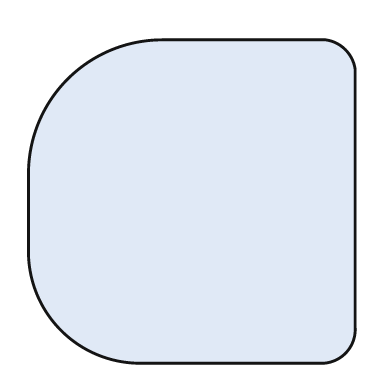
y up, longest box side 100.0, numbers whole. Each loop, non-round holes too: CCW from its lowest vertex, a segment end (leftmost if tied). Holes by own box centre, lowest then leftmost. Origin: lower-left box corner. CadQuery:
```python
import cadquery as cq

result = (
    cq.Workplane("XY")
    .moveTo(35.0, 0.0)
    .lineTo(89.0, 0.0)
    .threePointArc((97.0, 3.0), (100.0, 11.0))
    .lineTo(100.0, 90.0)
    .threePointArc((97.0, 96.0), (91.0, 99.0))
    .lineTo(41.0, 99.0)
    .threePointArc((12.0, 87.0), (0.0, 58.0))
    .lineTo(0.0, 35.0)
    .threePointArc((10.0, 10.0), (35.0, 0.0))
    .close()
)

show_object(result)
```